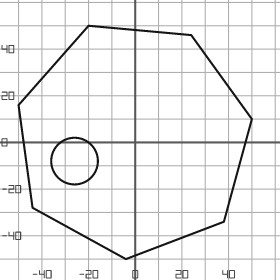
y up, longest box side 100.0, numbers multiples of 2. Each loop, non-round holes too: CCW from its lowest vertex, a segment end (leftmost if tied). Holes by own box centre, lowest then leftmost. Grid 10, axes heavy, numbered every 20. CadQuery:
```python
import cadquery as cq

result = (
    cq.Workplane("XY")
    .moveTo(-4.0, -50.0)
    .lineTo(38.0, -34.0)
    .lineTo(50.0, 10.0)
    .lineTo(24.0, 46.0)
    .lineTo(-20.0, 50.0)
    .lineTo(-50.0, 16.0)
    .lineTo(-44.0, -28.0)
    .close()
    .moveTo(-26.0, -8.0)
    .circle(10.0)
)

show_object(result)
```